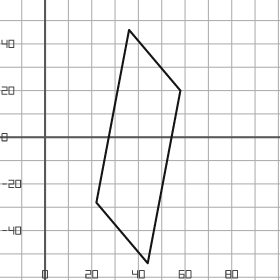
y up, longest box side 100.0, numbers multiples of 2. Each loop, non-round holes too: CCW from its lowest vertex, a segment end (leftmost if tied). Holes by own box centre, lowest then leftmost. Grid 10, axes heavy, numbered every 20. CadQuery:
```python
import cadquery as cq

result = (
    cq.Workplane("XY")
    .moveTo(44.0, -54.0)
    .lineTo(58.0, 20.0)
    .lineTo(36.0, 46.0)
    .lineTo(22.0, -28.0)
    .close()
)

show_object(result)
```